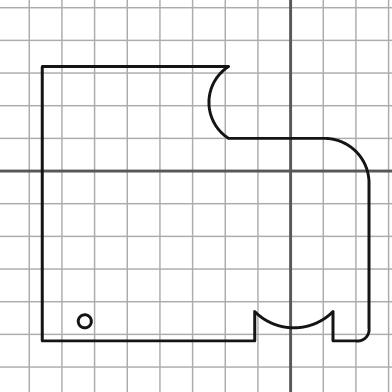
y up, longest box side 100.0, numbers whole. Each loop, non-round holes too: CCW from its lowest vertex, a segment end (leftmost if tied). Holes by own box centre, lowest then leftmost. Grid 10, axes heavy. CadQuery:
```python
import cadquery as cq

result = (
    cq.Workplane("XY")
    .moveTo(-76.0, -52.0)
    .lineTo(-11.0, -52.0)
    .lineTo(-11.0, -43.0)
    .threePointArc((1.0, -48.0), (13.0, -43.0))
    .lineTo(13.0, -52.0)
    .lineTo(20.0, -52.0)
    .threePointArc((23.0, -51.0), (24.0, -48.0))
    .lineTo(24.0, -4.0)
    .threePointArc((20.0, 6.0), (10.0, 10.0))
    .lineTo(-19.0, 10.0)
    .threePointArc((-25.0, 21.0), (-19.0, 32.0))
    .lineTo(-76.0, 32.0)
    .close()
    .moveTo(-63.0, -46.0)
    .circle(2.0)
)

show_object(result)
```